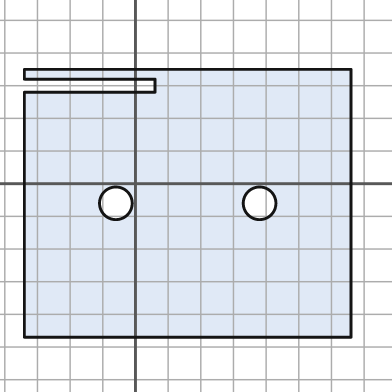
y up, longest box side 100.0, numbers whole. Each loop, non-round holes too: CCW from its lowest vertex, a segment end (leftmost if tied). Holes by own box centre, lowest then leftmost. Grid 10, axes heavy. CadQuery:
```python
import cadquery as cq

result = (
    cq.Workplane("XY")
    .moveTo(-34.0, -47.0)
    .lineTo(66.0, -47.0)
    .lineTo(66.0, 35.0)
    .lineTo(-34.0, 35.0)
    .lineTo(-34.0, 32.0)
    .lineTo(6.0, 32.0)
    .lineTo(6.0, 28.0)
    .lineTo(-34.0, 28.0)
    .close()
    .moveTo(-6.0, -6.0)
    .circle(5.0)
    .moveTo(38.0, -6.0)
    .circle(5.0)
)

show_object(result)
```